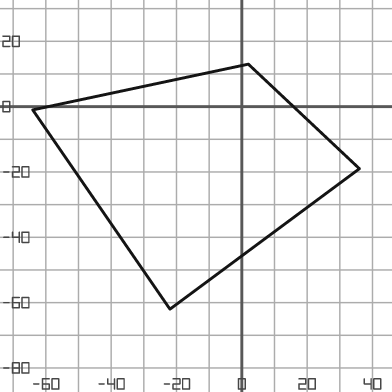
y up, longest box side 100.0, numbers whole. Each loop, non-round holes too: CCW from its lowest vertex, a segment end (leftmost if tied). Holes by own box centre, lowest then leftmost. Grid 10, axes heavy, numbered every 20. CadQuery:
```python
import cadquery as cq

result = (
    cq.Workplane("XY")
    .moveTo(-22.0, -62.0)
    .lineTo(36.0, -19.0)
    .lineTo(2.0, 13.0)
    .lineTo(-64.0, -1.0)
    .close()
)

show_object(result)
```